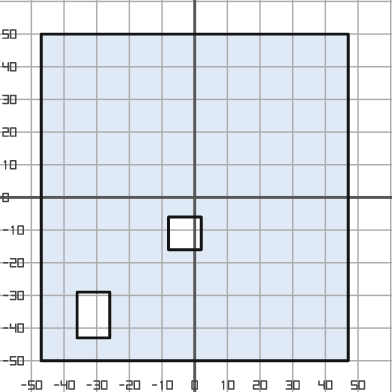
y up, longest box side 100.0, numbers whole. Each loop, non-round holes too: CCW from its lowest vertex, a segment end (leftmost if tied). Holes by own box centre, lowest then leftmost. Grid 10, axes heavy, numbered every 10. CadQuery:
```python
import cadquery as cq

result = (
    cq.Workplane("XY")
    .moveTo(-47.0, -50.0)
    .lineTo(47.0, -50.0)
    .lineTo(47.0, 50.0)
    .lineTo(-47.0, 50.0)
    .close()
    .moveTo(-36.0, -43.0)
    .lineTo(-26.0, -43.0)
    .lineTo(-26.0, -29.0)
    .lineTo(-36.0, -29.0)
    .close()
    .moveTo(-8.0, -16.0)
    .lineTo(2.0, -16.0)
    .lineTo(2.0, -6.0)
    .lineTo(-8.0, -6.0)
    .close()
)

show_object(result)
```